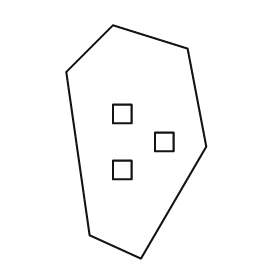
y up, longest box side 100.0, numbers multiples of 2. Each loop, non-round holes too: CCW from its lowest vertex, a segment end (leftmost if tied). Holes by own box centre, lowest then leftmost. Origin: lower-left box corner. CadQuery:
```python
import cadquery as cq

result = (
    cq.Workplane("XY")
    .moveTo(32.0, 0.0)
    .lineTo(60.0, 48.0)
    .lineTo(52.0, 90.0)
    .lineTo(20.0, 100.0)
    .lineTo(0.0, 80.0)
    .lineTo(10.0, 10.0)
    .close()
    .moveTo(20.0, 34.0)
    .lineTo(28.0, 34.0)
    .lineTo(28.0, 42.0)
    .lineTo(20.0, 42.0)
    .close()
    .moveTo(38.0, 46.0)
    .lineTo(46.0, 46.0)
    .lineTo(46.0, 54.0)
    .lineTo(38.0, 54.0)
    .close()
    .moveTo(20.0, 58.0)
    .lineTo(28.0, 58.0)
    .lineTo(28.0, 66.0)
    .lineTo(20.0, 66.0)
    .close()
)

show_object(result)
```